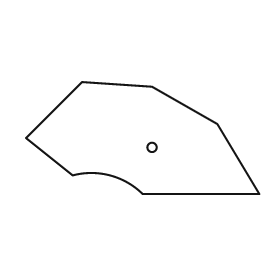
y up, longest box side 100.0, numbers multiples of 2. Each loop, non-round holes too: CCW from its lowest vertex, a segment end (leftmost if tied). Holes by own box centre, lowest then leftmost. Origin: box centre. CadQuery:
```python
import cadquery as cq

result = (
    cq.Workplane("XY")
    .moveTo(0.0, -24.0)
    .lineTo(50.0, -24.0)
    .lineTo(32.0, 6.0)
    .lineTo(4.0, 22.0)
    .lineTo(-26.0, 24.0)
    .lineTo(-50.0, 0.0)
    .lineTo(-30.0, -16.0)
    .threePointArc((-14.0, -16.0), (0.0, -24.0))
    .close()
    .moveTo(4.0, -4.0)
    .circle(2.0)
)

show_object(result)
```